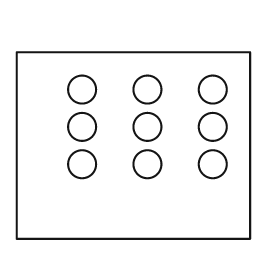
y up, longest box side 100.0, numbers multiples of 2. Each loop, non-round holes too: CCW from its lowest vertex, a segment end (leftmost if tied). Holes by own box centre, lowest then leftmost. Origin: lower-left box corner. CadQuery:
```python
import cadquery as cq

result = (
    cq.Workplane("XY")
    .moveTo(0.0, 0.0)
    .lineTo(100.0, 0.0)
    .lineTo(100.0, 80.0)
    .lineTo(0.0, 80.0)
    .close()
    .moveTo(28.0, 32.0)
    .circle(6.0)
    .moveTo(56.0, 32.0)
    .circle(6.0)
    .moveTo(84.0, 32.0)
    .circle(6.0)
    .moveTo(28.0, 48.0)
    .circle(6.0)
    .moveTo(56.0, 48.0)
    .circle(6.0)
    .moveTo(84.0, 48.0)
    .circle(6.0)
    .moveTo(28.0, 64.0)
    .circle(6.0)
    .moveTo(56.0, 64.0)
    .circle(6.0)
    .moveTo(84.0, 64.0)
    .circle(6.0)
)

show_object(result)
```